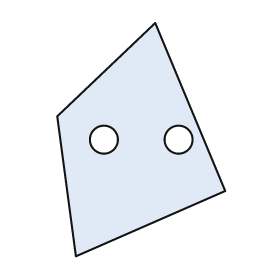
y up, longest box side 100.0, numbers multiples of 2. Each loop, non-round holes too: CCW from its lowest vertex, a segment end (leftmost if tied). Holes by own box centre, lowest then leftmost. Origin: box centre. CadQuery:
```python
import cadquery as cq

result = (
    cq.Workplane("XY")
    .moveTo(-28.0, -50.0)
    .lineTo(36.0, -22.0)
    .lineTo(6.0, 50.0)
    .lineTo(-36.0, 10.0)
    .close()
    .moveTo(-16.0, 0.0)
    .circle(6.0)
    .moveTo(16.0, 0.0)
    .circle(6.0)
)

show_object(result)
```